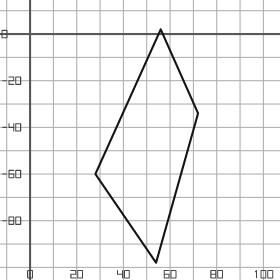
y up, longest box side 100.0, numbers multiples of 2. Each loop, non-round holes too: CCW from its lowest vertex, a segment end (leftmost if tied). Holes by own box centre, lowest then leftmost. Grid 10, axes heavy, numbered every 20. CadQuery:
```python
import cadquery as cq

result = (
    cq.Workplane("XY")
    .moveTo(54.0, -98.0)
    .lineTo(72.0, -34.0)
    .lineTo(56.0, 2.0)
    .lineTo(28.0, -60.0)
    .close()
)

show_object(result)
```